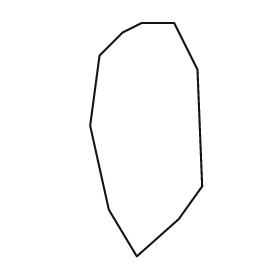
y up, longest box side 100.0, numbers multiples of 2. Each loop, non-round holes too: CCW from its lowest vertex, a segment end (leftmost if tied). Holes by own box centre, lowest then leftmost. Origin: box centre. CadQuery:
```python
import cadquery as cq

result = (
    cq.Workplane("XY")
    .moveTo(-4.0, -50.0)
    .lineTo(14.0, -34.0)
    .lineTo(24.0, -20.0)
    .lineTo(22.0, 30.0)
    .lineTo(12.0, 50.0)
    .lineTo(-2.0, 50.0)
    .lineTo(-10.0, 46.0)
    .lineTo(-20.0, 36.0)
    .lineTo(-24.0, 6.0)
    .lineTo(-16.0, -30.0)
    .close()
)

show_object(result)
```